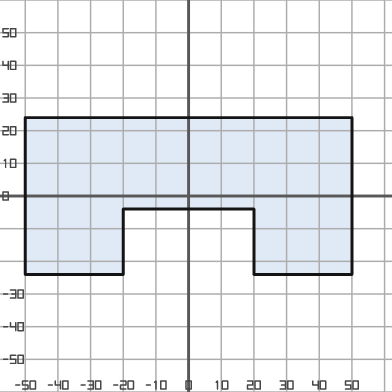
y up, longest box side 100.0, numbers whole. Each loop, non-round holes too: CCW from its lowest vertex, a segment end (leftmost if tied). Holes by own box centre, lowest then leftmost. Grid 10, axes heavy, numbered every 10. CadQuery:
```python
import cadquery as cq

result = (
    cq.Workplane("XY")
    .moveTo(-50.0, -24.0)
    .lineTo(-20.0, -24.0)
    .lineTo(-20.0, -4.0)
    .lineTo(20.0, -4.0)
    .lineTo(20.0, -24.0)
    .lineTo(50.0, -24.0)
    .lineTo(50.0, 24.0)
    .lineTo(-50.0, 24.0)
    .close()
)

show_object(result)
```